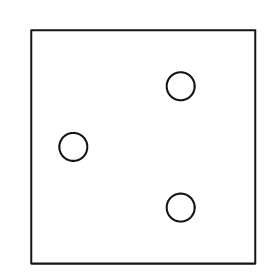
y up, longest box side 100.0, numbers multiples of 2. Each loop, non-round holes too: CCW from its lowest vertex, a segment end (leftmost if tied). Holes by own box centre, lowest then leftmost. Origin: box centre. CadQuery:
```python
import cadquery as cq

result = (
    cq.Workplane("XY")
    .moveTo(-48.0, -50.0)
    .lineTo(48.0, -50.0)
    .lineTo(48.0, 50.0)
    .lineTo(-48.0, 50.0)
    .close()
    .moveTo(16.0, -26.0)
    .circle(6.0)
    .moveTo(-30.0, 0.0)
    .circle(6.0)
    .moveTo(16.0, 26.0)
    .circle(6.0)
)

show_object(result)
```